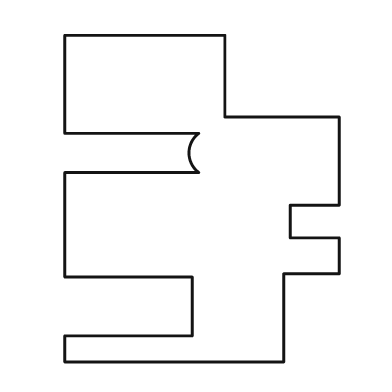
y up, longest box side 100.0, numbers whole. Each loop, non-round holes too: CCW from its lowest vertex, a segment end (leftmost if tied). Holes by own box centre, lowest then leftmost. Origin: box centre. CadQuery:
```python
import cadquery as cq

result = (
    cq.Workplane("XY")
    .moveTo(-42.0, -50.0)
    .lineTo(25.0, -50.0)
    .lineTo(25.0, -23.0)
    .lineTo(42.0, -23.0)
    .lineTo(42.0, -12.0)
    .lineTo(27.0, -12.0)
    .lineTo(27.0, -2.0)
    .lineTo(42.0, -2.0)
    .lineTo(42.0, 25.0)
    .lineTo(7.0, 25.0)
    .lineTo(7.0, 50.0)
    .lineTo(-42.0, 50.0)
    .lineTo(-42.0, 20.0)
    .lineTo(-1.0, 20.0)
    .threePointArc((-4.0, 14.0), (-1.0, 8.0))
    .lineTo(-42.0, 8.0)
    .lineTo(-42.0, -24.0)
    .lineTo(-3.0, -24.0)
    .lineTo(-3.0, -42.0)
    .lineTo(-42.0, -42.0)
    .close()
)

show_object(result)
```